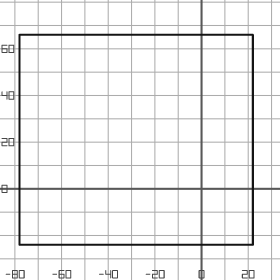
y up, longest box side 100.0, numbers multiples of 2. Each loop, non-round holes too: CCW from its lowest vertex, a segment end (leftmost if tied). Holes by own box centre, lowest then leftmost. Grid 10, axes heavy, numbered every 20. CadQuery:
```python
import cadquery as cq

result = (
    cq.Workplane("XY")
    .moveTo(-78.0, -24.0)
    .lineTo(22.0, -24.0)
    .lineTo(22.0, 66.0)
    .lineTo(-78.0, 66.0)
    .close()
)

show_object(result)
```